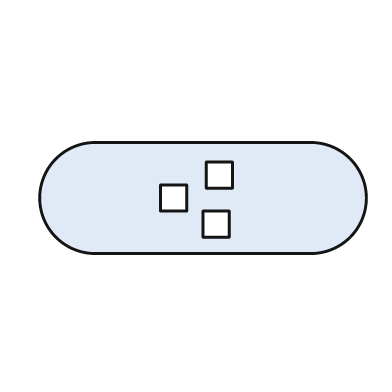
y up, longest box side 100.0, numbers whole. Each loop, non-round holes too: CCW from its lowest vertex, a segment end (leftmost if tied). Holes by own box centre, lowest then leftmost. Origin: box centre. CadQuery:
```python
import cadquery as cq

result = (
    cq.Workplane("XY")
    .moveTo(-33.0, -17.0)
    .lineTo(33.0, -17.0)
    .threePointArc((50.0, 0.0), (33.0, 17.0))
    .lineTo(-33.0, 17.0)
    .threePointArc((-50.0, 0.0), (-33.0, -17.0))
    .close()
    .moveTo(0.0, -12.0)
    .lineTo(8.0, -12.0)
    .lineTo(8.0, -4.0)
    .lineTo(0.0, -4.0)
    .close()
    .moveTo(-13.0, -4.0)
    .lineTo(-5.0, -4.0)
    .lineTo(-5.0, 4.0)
    .lineTo(-13.0, 4.0)
    .close()
    .moveTo(1.0, 3.0)
    .lineTo(9.0, 3.0)
    .lineTo(9.0, 11.0)
    .lineTo(1.0, 11.0)
    .close()
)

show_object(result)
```